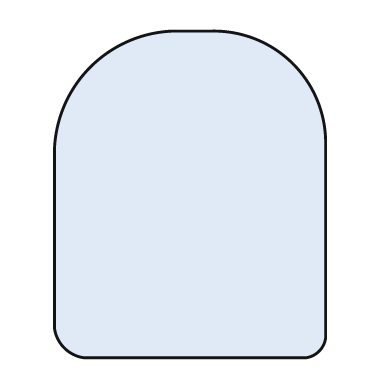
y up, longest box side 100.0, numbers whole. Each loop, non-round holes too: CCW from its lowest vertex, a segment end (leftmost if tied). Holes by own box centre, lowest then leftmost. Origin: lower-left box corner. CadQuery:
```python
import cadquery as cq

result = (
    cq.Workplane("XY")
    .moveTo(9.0, 0.0)
    .lineTo(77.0, 0.0)
    .threePointArc((81.0, 2.0), (83.0, 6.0))
    .lineTo(83.0, 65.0)
    .threePointArc((73.0, 90.0), (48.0, 100.0))
    .lineTo(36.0, 100.0)
    .threePointArc((11.0, 89.0), (0.0, 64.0))
    .lineTo(0.0, 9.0)
    .threePointArc((3.0, 3.0), (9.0, 0.0))
    .close()
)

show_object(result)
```